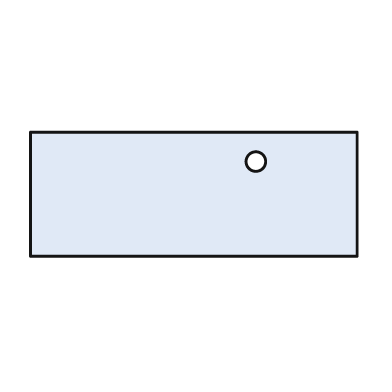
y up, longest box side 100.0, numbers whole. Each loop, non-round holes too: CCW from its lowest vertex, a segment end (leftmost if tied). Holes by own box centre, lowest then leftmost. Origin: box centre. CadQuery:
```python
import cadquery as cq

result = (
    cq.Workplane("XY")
    .moveTo(-50.0, -19.0)
    .lineTo(50.0, -19.0)
    .lineTo(50.0, 19.0)
    .lineTo(-50.0, 19.0)
    .close()
    .moveTo(19.0, 10.0)
    .circle(3.0)
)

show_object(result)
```